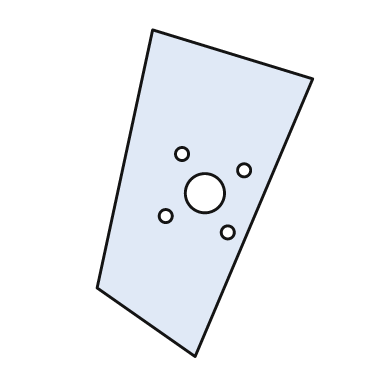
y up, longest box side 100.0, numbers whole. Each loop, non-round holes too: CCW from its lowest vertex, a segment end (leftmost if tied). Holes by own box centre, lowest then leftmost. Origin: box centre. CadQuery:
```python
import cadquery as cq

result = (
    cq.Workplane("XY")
    .moveTo(-3.0, -50.0)
    .lineTo(33.0, 35.0)
    .lineTo(-16.0, 50.0)
    .lineTo(-33.0, -29.0)
    .close()
    .moveTo(7.0, -12.0)
    .circle(2.0)
    .moveTo(-12.0, -7.0)
    .circle(2.0)
    .moveTo(0.0, 0.0)
    .circle(6.0)
    .moveTo(12.0, 7.0)
    .circle(2.0)
    .moveTo(-7.0, 12.0)
    .circle(2.0)
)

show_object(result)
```